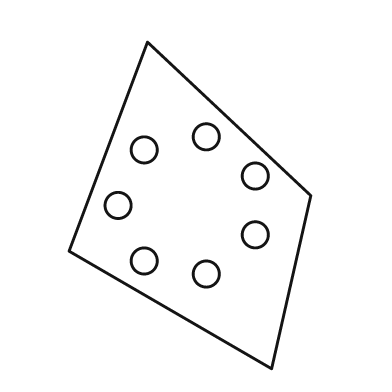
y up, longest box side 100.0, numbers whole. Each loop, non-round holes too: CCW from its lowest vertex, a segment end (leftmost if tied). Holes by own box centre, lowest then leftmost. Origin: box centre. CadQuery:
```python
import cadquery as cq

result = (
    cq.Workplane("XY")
    .moveTo(25.0, -50.0)
    .lineTo(37.0, 3.0)
    .lineTo(-13.0, 50.0)
    .lineTo(-37.0, -14.0)
    .close()
    .moveTo(5.0, -21.0)
    .circle(4.0)
    .moveTo(-14.0, -17.0)
    .circle(4.0)
    .moveTo(20.0, -9.0)
    .circle(4.0)
    .moveTo(-22.0, 0.0)
    .circle(4.0)
    .moveTo(20.0, 9.0)
    .circle(4.0)
    .moveTo(-14.0, 17.0)
    .circle(4.0)
    .moveTo(5.0, 21.0)
    .circle(4.0)
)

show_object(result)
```